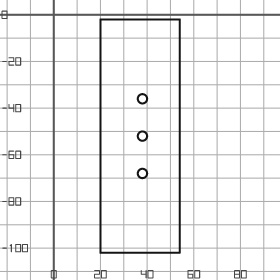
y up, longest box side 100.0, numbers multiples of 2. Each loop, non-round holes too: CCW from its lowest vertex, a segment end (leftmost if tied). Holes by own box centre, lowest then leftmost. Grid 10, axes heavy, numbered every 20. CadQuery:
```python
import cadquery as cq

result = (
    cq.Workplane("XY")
    .moveTo(20.0, -102.0)
    .lineTo(54.0, -102.0)
    .lineTo(54.0, -2.0)
    .lineTo(20.0, -2.0)
    .close()
    .moveTo(38.0, -68.0)
    .circle(2.0)
    .moveTo(38.0, -52.0)
    .circle(2.0)
    .moveTo(38.0, -36.0)
    .circle(2.0)
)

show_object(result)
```